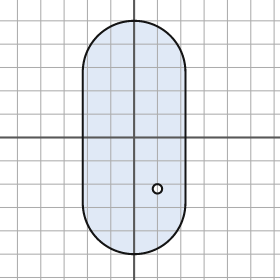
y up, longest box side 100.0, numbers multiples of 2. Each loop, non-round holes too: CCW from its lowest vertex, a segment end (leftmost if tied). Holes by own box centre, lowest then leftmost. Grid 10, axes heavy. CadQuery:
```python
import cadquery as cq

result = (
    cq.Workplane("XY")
    .moveTo(-22.0, -28.0)
    .threePointArc((0.0, -50.0), (22.0, -28.0))
    .lineTo(22.0, 28.0)
    .threePointArc((0.0, 50.0), (-22.0, 28.0))
    .close()
    .moveTo(10.0, -22.0)
    .circle(2.0)
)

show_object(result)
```